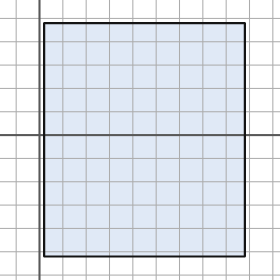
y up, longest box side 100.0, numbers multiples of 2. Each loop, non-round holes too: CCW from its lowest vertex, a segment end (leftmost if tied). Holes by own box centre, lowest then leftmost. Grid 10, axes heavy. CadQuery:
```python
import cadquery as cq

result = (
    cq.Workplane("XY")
    .moveTo(2.0, -52.0)
    .lineTo(88.0, -52.0)
    .lineTo(88.0, 48.0)
    .lineTo(2.0, 48.0)
    .close()
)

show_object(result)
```